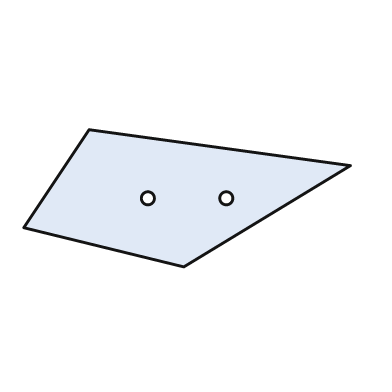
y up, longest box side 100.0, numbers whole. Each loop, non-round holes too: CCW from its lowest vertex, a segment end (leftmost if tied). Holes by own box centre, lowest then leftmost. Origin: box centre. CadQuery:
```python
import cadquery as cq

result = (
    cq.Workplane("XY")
    .moveTo(-1.0, -21.0)
    .lineTo(50.0, 10.0)
    .lineTo(-30.0, 21.0)
    .lineTo(-50.0, -9.0)
    .close()
    .moveTo(-12.0, 0.0)
    .circle(2.0)
    .moveTo(12.0, 0.0)
    .circle(2.0)
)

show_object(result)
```